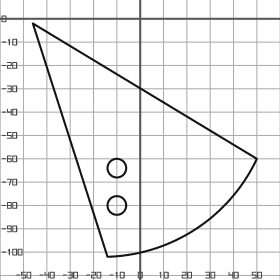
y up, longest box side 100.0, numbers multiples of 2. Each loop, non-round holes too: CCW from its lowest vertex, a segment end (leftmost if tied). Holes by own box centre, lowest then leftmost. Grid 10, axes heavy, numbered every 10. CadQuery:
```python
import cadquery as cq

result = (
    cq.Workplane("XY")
    .moveTo(-14.0, -102.0)
    .threePointArc((24.0, -90.0), (50.0, -60.0))
    .lineTo(-46.0, -2.0)
    .close()
    .moveTo(-10.0, -80.0)
    .circle(4.0)
    .moveTo(-10.0, -64.0)
    .circle(4.0)
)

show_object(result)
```